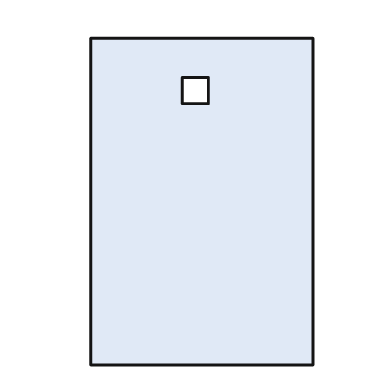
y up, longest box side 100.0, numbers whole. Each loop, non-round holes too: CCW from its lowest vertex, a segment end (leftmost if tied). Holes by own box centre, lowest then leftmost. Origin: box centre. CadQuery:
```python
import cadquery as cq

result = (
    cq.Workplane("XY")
    .moveTo(-34.0, -50.0)
    .lineTo(34.0, -50.0)
    .lineTo(34.0, 50.0)
    .lineTo(-34.0, 50.0)
    .close()
    .moveTo(-6.0, 30.0)
    .lineTo(2.0, 30.0)
    .lineTo(2.0, 38.0)
    .lineTo(-6.0, 38.0)
    .close()
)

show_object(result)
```